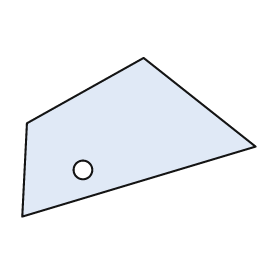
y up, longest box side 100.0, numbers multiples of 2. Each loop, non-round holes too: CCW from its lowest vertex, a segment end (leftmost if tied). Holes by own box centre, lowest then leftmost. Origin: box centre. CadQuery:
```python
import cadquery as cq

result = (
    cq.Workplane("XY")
    .moveTo(-50.0, -34.0)
    .lineTo(50.0, -4.0)
    .lineTo(2.0, 34.0)
    .lineTo(-48.0, 6.0)
    .close()
    .moveTo(-24.0, -14.0)
    .circle(4.0)
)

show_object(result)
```